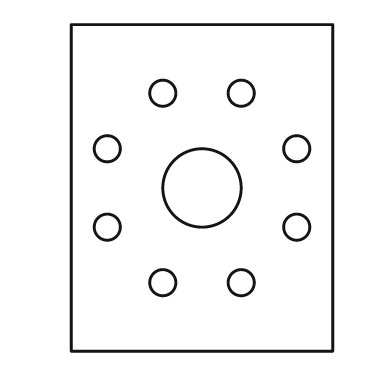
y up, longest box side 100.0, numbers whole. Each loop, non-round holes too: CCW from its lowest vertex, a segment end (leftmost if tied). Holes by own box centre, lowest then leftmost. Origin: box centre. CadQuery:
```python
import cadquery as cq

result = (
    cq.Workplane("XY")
    .moveTo(-40.0, -50.0)
    .lineTo(40.0, -50.0)
    .lineTo(40.0, 50.0)
    .lineTo(-40.0, 50.0)
    .close()
    .moveTo(-12.0, -29.0)
    .circle(4.0)
    .moveTo(12.0, -29.0)
    .circle(4.0)
    .moveTo(-29.0, -12.0)
    .circle(4.0)
    .moveTo(29.0, -12.0)
    .circle(4.0)
    .moveTo(0.0, 0.0)
    .circle(12.0)
    .moveTo(-29.0, 12.0)
    .circle(4.0)
    .moveTo(29.0, 12.0)
    .circle(4.0)
    .moveTo(-12.0, 29.0)
    .circle(4.0)
    .moveTo(12.0, 29.0)
    .circle(4.0)
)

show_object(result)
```